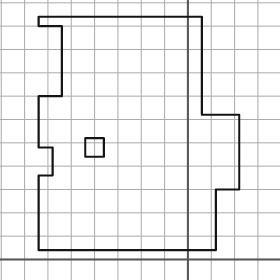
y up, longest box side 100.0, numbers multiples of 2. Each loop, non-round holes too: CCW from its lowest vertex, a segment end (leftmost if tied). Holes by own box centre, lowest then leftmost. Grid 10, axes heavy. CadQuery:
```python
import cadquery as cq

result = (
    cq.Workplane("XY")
    .moveTo(-64.0, 4.0)
    .lineTo(12.0, 4.0)
    .lineTo(12.0, 30.0)
    .lineTo(22.0, 30.0)
    .lineTo(22.0, 62.0)
    .lineTo(6.0, 62.0)
    .lineTo(6.0, 104.0)
    .lineTo(-64.0, 104.0)
    .lineTo(-64.0, 100.0)
    .lineTo(-54.0, 100.0)
    .lineTo(-54.0, 70.0)
    .lineTo(-64.0, 70.0)
    .lineTo(-64.0, 48.0)
    .lineTo(-58.0, 48.0)
    .lineTo(-58.0, 36.0)
    .lineTo(-64.0, 36.0)
    .close()
    .moveTo(-44.0, 44.0)
    .lineTo(-36.0, 44.0)
    .lineTo(-36.0, 52.0)
    .lineTo(-44.0, 52.0)
    .close()
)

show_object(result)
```